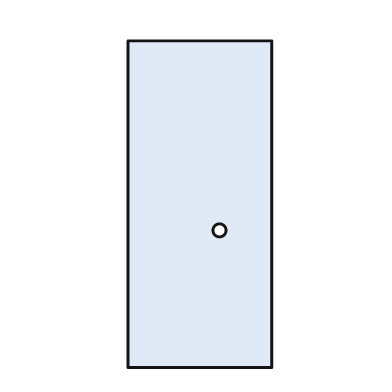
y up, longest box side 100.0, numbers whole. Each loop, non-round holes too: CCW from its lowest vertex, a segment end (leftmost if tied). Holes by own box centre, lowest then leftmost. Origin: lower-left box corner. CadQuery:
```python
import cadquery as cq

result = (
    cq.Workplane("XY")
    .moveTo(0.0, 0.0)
    .lineTo(44.0, 0.0)
    .lineTo(44.0, 100.0)
    .lineTo(0.0, 100.0)
    .close()
    .moveTo(28.0, 42.0)
    .circle(2.0)
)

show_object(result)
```